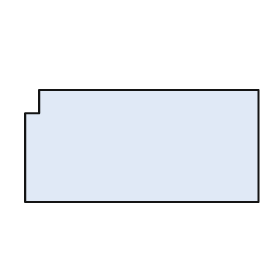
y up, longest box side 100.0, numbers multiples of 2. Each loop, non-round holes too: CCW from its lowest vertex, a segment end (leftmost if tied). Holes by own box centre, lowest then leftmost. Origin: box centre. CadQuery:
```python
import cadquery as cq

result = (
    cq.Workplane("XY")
    .moveTo(-50.0, -24.0)
    .lineTo(50.0, -24.0)
    .lineTo(50.0, 24.0)
    .lineTo(-44.0, 24.0)
    .lineTo(-44.0, 14.0)
    .lineTo(-50.0, 14.0)
    .close()
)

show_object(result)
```